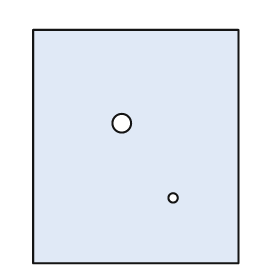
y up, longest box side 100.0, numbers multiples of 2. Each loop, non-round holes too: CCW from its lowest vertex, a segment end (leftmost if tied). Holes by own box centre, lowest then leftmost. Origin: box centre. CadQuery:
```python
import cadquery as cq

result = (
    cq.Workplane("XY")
    .moveTo(-44.0, -50.0)
    .lineTo(44.0, -50.0)
    .lineTo(44.0, 50.0)
    .lineTo(-44.0, 50.0)
    .close()
    .moveTo(16.0, -22.0)
    .circle(2.0)
    .moveTo(-6.0, 10.0)
    .circle(4.0)
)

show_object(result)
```